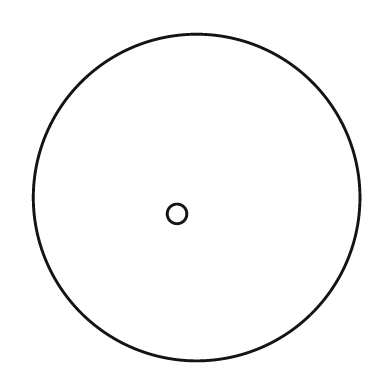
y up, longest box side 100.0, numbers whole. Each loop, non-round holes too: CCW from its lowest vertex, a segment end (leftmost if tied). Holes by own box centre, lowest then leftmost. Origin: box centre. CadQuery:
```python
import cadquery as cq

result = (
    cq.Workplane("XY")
    .moveTo(0.0, 0.0)
    .circle(50.0)
    .moveTo(-6.0, -5.0)
    .circle(3.0)
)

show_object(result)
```